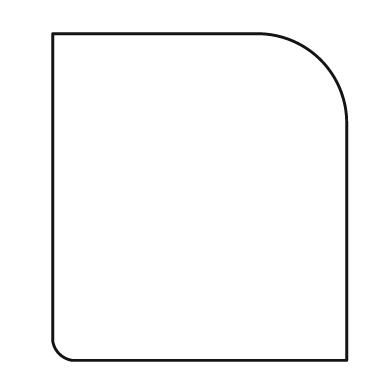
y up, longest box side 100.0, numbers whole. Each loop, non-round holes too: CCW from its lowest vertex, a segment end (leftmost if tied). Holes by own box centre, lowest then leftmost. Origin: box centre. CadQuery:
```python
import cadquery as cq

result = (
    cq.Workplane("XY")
    .moveTo(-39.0, -50.0)
    .lineTo(45.0, -50.0)
    .lineTo(45.0, 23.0)
    .threePointArc((37.0, 42.0), (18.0, 50.0))
    .lineTo(-45.0, 50.0)
    .lineTo(-45.0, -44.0)
    .threePointArc((-43.0, -48.0), (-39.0, -50.0))
    .close()
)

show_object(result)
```